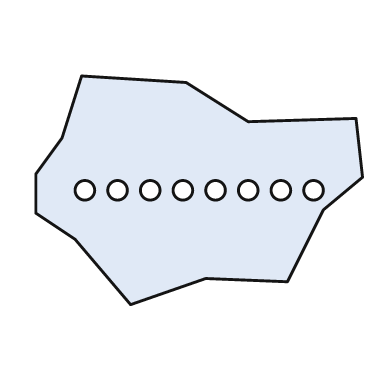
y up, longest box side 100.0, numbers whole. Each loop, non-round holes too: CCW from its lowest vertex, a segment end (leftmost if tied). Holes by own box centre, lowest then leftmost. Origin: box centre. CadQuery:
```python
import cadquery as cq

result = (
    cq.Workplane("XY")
    .moveTo(-21.0, -35.0)
    .lineTo(2.0, -27.0)
    .lineTo(27.0, -28.0)
    .lineTo(38.0, -6.0)
    .lineTo(50.0, 4.0)
    .lineTo(48.0, 22.0)
    .lineTo(15.0, 21.0)
    .lineTo(-4.0, 33.0)
    .lineTo(-36.0, 35.0)
    .lineTo(-42.0, 16.0)
    .lineTo(-50.0, 5.0)
    .lineTo(-50.0, -7.0)
    .lineTo(-38.0, -15.0)
    .close()
    .moveTo(-35.0, 0.0)
    .circle(3.0)
    .moveTo(-25.0, 0.0)
    .circle(3.0)
    .moveTo(-15.0, 0.0)
    .circle(3.0)
    .moveTo(-5.0, 0.0)
    .circle(3.0)
    .moveTo(5.0, 0.0)
    .circle(3.0)
    .moveTo(15.0, 0.0)
    .circle(3.0)
    .moveTo(25.0, 0.0)
    .circle(3.0)
    .moveTo(35.0, 0.0)
    .circle(3.0)
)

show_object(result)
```